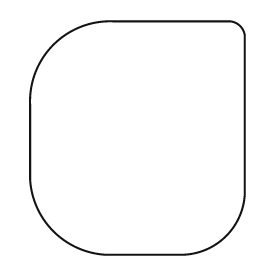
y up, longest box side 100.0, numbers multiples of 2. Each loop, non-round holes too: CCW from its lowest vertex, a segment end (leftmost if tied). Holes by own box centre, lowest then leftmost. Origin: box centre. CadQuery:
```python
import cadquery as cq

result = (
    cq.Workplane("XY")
    .moveTo(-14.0, -50.0)
    .lineTo(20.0, -50.0)
    .threePointArc((38.0, -42.0), (46.0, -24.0))
    .lineTo(46.0, 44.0)
    .threePointArc((44.0, 48.0), (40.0, 50.0))
    .lineTo(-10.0, 50.0)
    .threePointArc((-36.0, 40.0), (-46.0, 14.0))
    .lineTo(-46.0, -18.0)
    .threePointArc((-36.0, -40.0), (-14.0, -50.0))
    .close()
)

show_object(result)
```